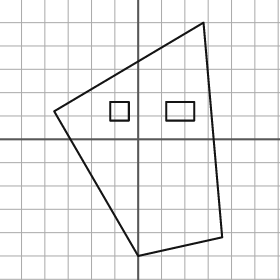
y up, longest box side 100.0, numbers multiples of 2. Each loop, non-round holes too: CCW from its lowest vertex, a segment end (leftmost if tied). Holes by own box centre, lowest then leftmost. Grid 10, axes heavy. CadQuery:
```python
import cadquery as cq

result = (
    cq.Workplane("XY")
    .moveTo(0.0, -50.0)
    .lineTo(36.0, -42.0)
    .lineTo(28.0, 50.0)
    .lineTo(-36.0, 12.0)
    .close()
    .moveTo(-12.0, 8.0)
    .lineTo(-4.0, 8.0)
    .lineTo(-4.0, 16.0)
    .lineTo(-12.0, 16.0)
    .close()
    .moveTo(12.0, 8.0)
    .lineTo(24.0, 8.0)
    .lineTo(24.0, 16.0)
    .lineTo(12.0, 16.0)
    .close()
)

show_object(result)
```